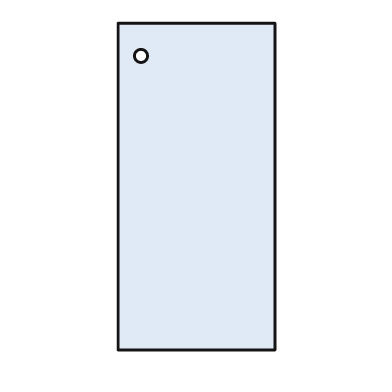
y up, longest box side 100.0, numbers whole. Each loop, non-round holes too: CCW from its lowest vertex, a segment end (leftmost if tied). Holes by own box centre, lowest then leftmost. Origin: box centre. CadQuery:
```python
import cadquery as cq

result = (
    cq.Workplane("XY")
    .moveTo(-24.0, -50.0)
    .lineTo(24.0, -50.0)
    .lineTo(24.0, 50.0)
    .lineTo(-24.0, 50.0)
    .close()
    .moveTo(-17.0, 40.0)
    .circle(2.0)
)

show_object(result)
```